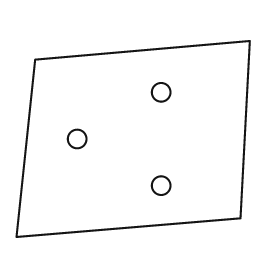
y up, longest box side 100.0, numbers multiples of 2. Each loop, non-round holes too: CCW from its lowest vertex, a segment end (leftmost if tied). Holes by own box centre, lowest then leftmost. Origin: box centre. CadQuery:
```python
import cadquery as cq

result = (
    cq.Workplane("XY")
    .moveTo(-50.0, -42.0)
    .lineTo(46.0, -34.0)
    .lineTo(50.0, 42.0)
    .lineTo(-42.0, 34.0)
    .close()
    .moveTo(12.0, -20.0)
    .circle(4.0)
    .moveTo(-24.0, 0.0)
    .circle(4.0)
    .moveTo(12.0, 20.0)
    .circle(4.0)
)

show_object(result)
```